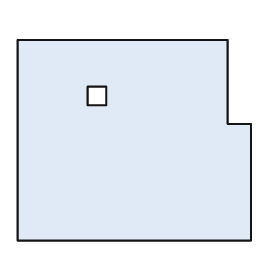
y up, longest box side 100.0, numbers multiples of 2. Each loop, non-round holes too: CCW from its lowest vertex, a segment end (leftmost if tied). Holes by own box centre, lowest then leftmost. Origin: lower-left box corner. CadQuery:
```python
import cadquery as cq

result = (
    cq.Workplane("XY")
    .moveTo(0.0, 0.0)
    .lineTo(100.0, 0.0)
    .lineTo(100.0, 50.0)
    .lineTo(90.0, 50.0)
    .lineTo(90.0, 86.0)
    .lineTo(0.0, 86.0)
    .close()
    .moveTo(30.0, 58.0)
    .lineTo(38.0, 58.0)
    .lineTo(38.0, 66.0)
    .lineTo(30.0, 66.0)
    .close()
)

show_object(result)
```